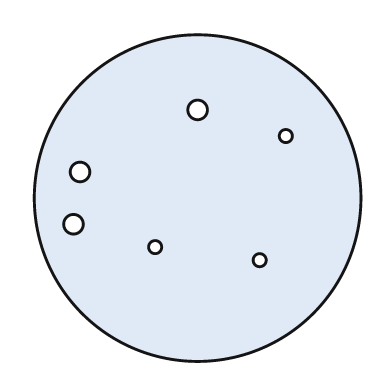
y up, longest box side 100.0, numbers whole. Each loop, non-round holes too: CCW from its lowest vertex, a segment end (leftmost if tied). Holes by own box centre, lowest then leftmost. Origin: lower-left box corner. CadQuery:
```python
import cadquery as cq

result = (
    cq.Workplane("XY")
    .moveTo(50.0, 50.0)
    .circle(50.0)
    .moveTo(69.0, 31.0)
    .circle(2.0)
    .moveTo(37.0, 35.0)
    .circle(2.0)
    .moveTo(12.0, 42.0)
    .circle(3.0)
    .moveTo(14.0, 58.0)
    .circle(3.0)
    .moveTo(77.0, 69.0)
    .circle(2.0)
    .moveTo(50.0, 77.0)
    .circle(3.0)
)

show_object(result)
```